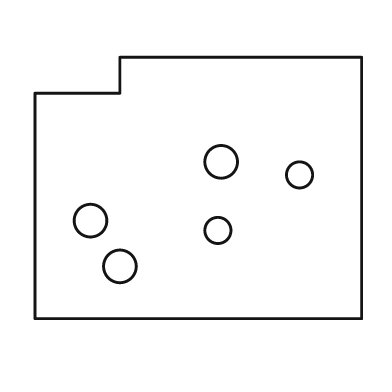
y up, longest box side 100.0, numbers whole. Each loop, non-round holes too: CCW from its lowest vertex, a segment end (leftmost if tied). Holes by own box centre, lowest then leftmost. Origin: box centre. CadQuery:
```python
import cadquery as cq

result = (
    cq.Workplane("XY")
    .moveTo(-50.0, -40.0)
    .lineTo(50.0, -40.0)
    .lineTo(50.0, 40.0)
    .lineTo(-24.0, 40.0)
    .lineTo(-24.0, 29.0)
    .lineTo(-50.0, 29.0)
    .close()
    .moveTo(-24.0, -24.0)
    .circle(5.0)
    .moveTo(6.0, -13.0)
    .circle(4.0)
    .moveTo(-33.0, -10.0)
    .circle(5.0)
    .moveTo(31.0, 4.0)
    .circle(4.0)
    .moveTo(7.0, 8.0)
    .circle(5.0)
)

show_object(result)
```